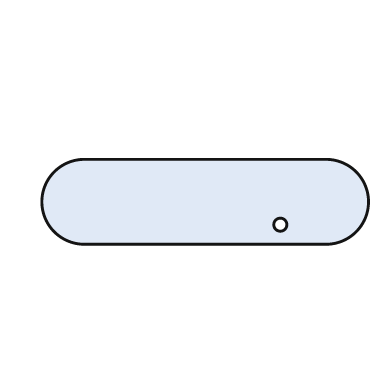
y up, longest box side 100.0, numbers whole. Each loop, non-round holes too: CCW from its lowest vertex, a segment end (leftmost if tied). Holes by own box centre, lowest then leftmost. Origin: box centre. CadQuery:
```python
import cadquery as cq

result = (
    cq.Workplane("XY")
    .moveTo(-37.0, -13.0)
    .lineTo(37.0, -13.0)
    .threePointArc((50.0, 0.0), (37.0, 13.0))
    .lineTo(-37.0, 13.0)
    .threePointArc((-50.0, 0.0), (-37.0, -13.0))
    .close()
    .moveTo(23.0, -7.0)
    .circle(2.0)
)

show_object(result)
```